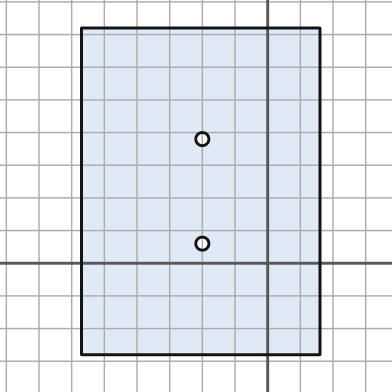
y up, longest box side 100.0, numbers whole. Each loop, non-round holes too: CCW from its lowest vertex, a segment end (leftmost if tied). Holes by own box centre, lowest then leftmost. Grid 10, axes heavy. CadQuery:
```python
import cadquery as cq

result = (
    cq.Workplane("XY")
    .moveTo(-57.0, -28.0)
    .lineTo(16.0, -28.0)
    .lineTo(16.0, 72.0)
    .lineTo(-57.0, 72.0)
    .close()
    .moveTo(-20.0, 6.0)
    .circle(2.0)
    .moveTo(-20.0, 38.0)
    .circle(2.0)
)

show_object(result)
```